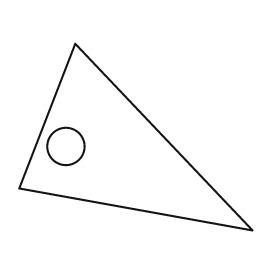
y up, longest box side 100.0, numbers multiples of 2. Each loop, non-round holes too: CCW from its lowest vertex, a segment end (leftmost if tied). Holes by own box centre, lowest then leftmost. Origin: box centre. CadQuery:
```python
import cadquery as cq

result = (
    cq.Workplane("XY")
    .moveTo(50.0, -40.0)
    .lineTo(-26.0, 40.0)
    .lineTo(-50.0, -22.0)
    .close()
    .moveTo(-30.0, -4.0)
    .circle(8.0)
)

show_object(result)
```